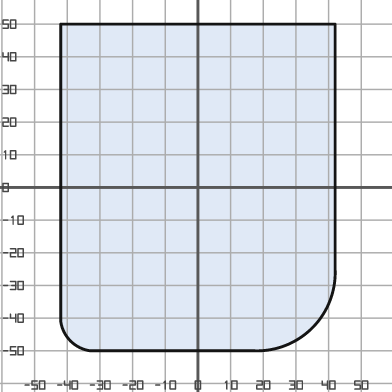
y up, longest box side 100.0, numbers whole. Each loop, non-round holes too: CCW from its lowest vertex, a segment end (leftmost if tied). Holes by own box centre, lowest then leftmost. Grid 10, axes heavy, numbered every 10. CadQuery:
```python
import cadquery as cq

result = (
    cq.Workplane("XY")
    .moveTo(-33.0, -50.0)
    .lineTo(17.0, -50.0)
    .threePointArc((35.0, -43.0), (42.0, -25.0))
    .lineTo(42.0, 50.0)
    .lineTo(-42.0, 50.0)
    .lineTo(-42.0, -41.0)
    .threePointArc((-39.0, -47.0), (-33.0, -50.0))
    .close()
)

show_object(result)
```